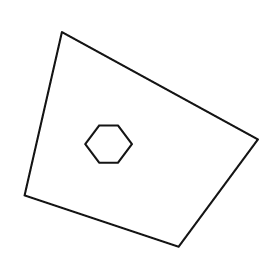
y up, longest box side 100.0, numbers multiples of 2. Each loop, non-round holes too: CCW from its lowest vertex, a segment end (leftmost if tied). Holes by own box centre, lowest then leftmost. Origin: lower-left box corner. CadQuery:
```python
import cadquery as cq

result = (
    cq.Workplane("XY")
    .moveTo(66.0, 0.0)
    .lineTo(100.0, 46.0)
    .lineTo(16.0, 92.0)
    .lineTo(0.0, 22.0)
    .close()
    .moveTo(32.0, 36.0)
    .lineTo(40.0, 36.0)
    .lineTo(46.0, 44.0)
    .lineTo(40.0, 52.0)
    .lineTo(32.0, 52.0)
    .lineTo(26.0, 44.0)
    .close()
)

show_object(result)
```